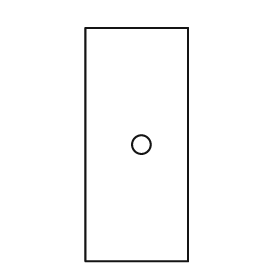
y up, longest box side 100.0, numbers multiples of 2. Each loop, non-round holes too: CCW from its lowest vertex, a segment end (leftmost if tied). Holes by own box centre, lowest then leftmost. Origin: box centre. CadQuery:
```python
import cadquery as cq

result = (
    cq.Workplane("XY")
    .moveTo(-22.0, -50.0)
    .lineTo(22.0, -50.0)
    .lineTo(22.0, 50.0)
    .lineTo(-22.0, 50.0)
    .close()
    .moveTo(2.0, 0.0)
    .circle(4.0)
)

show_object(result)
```